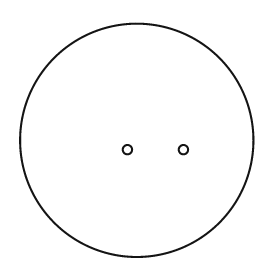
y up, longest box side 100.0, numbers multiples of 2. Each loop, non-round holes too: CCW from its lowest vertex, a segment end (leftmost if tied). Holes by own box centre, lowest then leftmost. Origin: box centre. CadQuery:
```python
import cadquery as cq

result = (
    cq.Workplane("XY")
    .moveTo(0.0, 0.0)
    .circle(50.0)
    .moveTo(-4.0, -4.0)
    .circle(2.0)
    .moveTo(20.0, -4.0)
    .circle(2.0)
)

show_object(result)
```